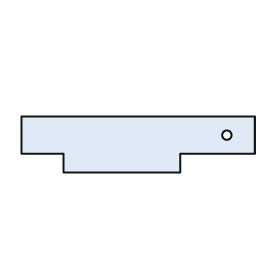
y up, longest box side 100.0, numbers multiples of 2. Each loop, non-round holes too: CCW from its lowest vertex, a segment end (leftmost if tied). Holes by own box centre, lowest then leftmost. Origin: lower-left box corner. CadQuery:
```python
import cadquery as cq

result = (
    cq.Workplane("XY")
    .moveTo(18.0, 0.0)
    .lineTo(68.0, 0.0)
    .lineTo(68.0, 8.0)
    .lineTo(100.0, 8.0)
    .lineTo(100.0, 24.0)
    .lineTo(0.0, 24.0)
    .lineTo(0.0, 8.0)
    .lineTo(18.0, 8.0)
    .close()
    .moveTo(88.0, 16.0)
    .circle(2.0)
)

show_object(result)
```